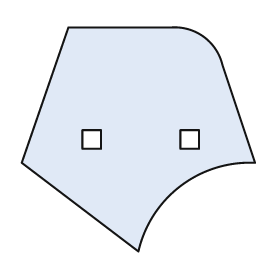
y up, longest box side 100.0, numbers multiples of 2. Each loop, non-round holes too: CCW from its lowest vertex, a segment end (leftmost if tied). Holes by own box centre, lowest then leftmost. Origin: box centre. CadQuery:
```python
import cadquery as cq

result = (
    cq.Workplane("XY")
    .moveTo(0.0, -48.0)
    .threePointArc((18.0, -20.0), (50.0, -10.0))
    .lineTo(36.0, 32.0)
    .threePointArc((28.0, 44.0), (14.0, 48.0))
    .lineTo(-30.0, 48.0)
    .lineTo(-50.0, -10.0)
    .close()
    .moveTo(-24.0, -4.0)
    .lineTo(-16.0, -4.0)
    .lineTo(-16.0, 4.0)
    .lineTo(-24.0, 4.0)
    .close()
    .moveTo(18.0, -4.0)
    .lineTo(26.0, -4.0)
    .lineTo(26.0, 4.0)
    .lineTo(18.0, 4.0)
    .close()
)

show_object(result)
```